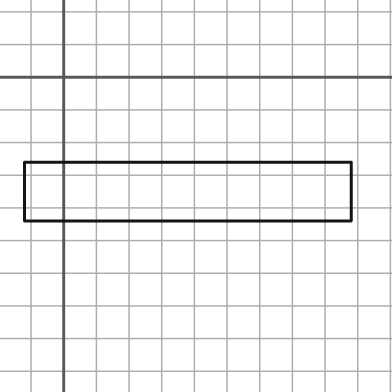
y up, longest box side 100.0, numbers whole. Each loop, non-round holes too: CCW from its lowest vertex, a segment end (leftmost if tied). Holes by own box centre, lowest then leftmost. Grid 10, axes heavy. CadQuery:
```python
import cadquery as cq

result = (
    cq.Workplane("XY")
    .moveTo(-12.0, -44.0)
    .lineTo(88.0, -44.0)
    .lineTo(88.0, -26.0)
    .lineTo(-12.0, -26.0)
    .close()
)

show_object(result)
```